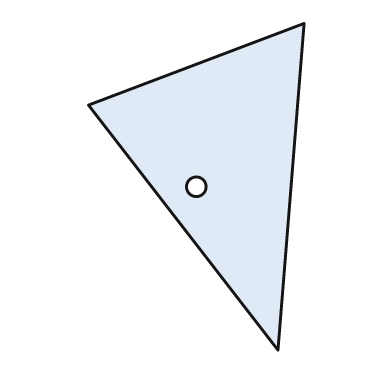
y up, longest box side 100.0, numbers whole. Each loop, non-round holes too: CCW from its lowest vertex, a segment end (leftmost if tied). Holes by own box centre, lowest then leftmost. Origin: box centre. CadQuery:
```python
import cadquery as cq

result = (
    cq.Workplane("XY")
    .moveTo(25.0, -50.0)
    .lineTo(33.0, 50.0)
    .lineTo(-33.0, 25.0)
    .close()
    .moveTo(0.0, 0.0)
    .circle(3.0)
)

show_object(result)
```